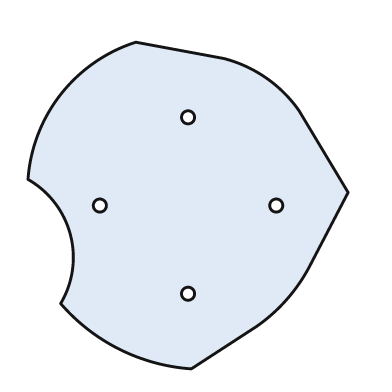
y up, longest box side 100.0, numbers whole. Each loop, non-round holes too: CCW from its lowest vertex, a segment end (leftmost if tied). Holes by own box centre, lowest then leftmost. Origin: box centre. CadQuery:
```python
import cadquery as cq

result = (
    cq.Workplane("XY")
    .moveTo(1.0, -50.0)
    .lineTo(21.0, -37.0)
    .threePointArc((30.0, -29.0), (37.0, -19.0))
    .lineTo(49.0, 4.0)
    .lineTo(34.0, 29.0)
    .threePointArc((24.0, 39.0), (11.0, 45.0))
    .lineTo(-16.0, 50.0)
    .threePointArc((-39.0, 34.0), (-49.0, 8.0))
    .threePointArc((-36.0, -9.0), (-39.0, -30.0))
    .threePointArc((-21.0, -44.0), (1.0, -50.0))
    .close()
    .moveTo(0.0, -27.0)
    .circle(2.0)
    .moveTo(-27.0, 0.0)
    .circle(2.0)
    .moveTo(27.0, 0.0)
    .circle(2.0)
    .moveTo(0.0, 27.0)
    .circle(2.0)
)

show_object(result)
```